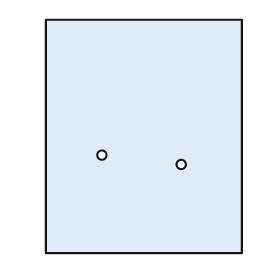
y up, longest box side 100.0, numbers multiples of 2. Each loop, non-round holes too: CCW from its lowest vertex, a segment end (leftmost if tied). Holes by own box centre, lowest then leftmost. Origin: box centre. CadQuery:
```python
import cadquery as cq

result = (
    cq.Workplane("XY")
    .moveTo(-42.0, -50.0)
    .lineTo(42.0, -50.0)
    .lineTo(42.0, 50.0)
    .lineTo(-42.0, 50.0)
    .close()
    .moveTo(16.0, -12.0)
    .circle(2.0)
    .moveTo(-18.0, -8.0)
    .circle(2.0)
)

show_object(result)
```